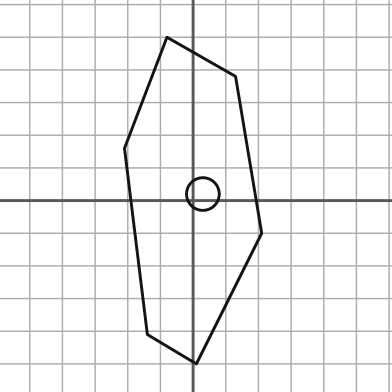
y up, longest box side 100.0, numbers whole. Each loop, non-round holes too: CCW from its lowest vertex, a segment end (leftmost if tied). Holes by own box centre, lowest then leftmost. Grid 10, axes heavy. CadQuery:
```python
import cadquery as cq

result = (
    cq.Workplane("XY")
    .moveTo(1.0, -50.0)
    .lineTo(21.0, -10.0)
    .lineTo(13.0, 38.0)
    .lineTo(-8.0, 50.0)
    .lineTo(-21.0, 16.0)
    .lineTo(-14.0, -41.0)
    .close()
    .moveTo(3.0, 2.0)
    .circle(5.0)
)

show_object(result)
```